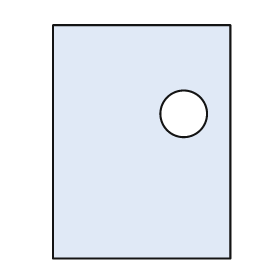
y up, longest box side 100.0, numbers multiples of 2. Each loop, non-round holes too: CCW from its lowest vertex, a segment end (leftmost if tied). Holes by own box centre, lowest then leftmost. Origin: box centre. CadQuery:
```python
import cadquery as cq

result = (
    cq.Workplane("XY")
    .moveTo(-38.0, -50.0)
    .lineTo(38.0, -50.0)
    .lineTo(38.0, 50.0)
    .lineTo(-38.0, 50.0)
    .close()
    .moveTo(18.0, 12.0)
    .circle(10.0)
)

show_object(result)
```